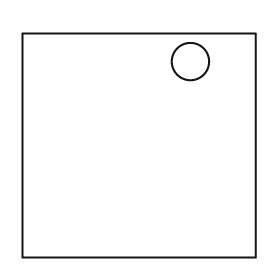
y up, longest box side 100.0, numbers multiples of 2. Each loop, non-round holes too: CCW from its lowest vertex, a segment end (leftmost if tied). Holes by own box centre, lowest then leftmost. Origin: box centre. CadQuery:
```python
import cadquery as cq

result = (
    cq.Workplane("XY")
    .moveTo(-50.0, -48.0)
    .lineTo(50.0, -48.0)
    .lineTo(50.0, 48.0)
    .lineTo(-50.0, 48.0)
    .close()
    .moveTo(22.0, 36.0)
    .circle(8.0)
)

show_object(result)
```